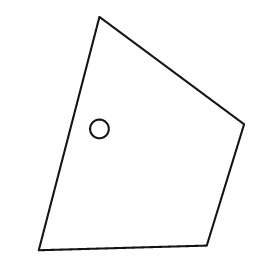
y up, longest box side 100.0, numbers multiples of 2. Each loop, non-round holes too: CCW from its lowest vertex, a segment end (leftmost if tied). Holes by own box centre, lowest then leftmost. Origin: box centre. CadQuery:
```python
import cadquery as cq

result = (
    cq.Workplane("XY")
    .moveTo(-44.0, -50.0)
    .lineTo(28.0, -48.0)
    .lineTo(44.0, 4.0)
    .lineTo(-18.0, 50.0)
    .close()
    .moveTo(-18.0, 2.0)
    .circle(4.0)
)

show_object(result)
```